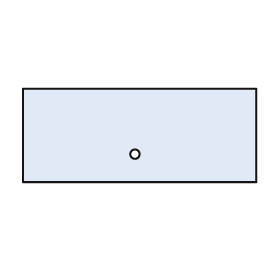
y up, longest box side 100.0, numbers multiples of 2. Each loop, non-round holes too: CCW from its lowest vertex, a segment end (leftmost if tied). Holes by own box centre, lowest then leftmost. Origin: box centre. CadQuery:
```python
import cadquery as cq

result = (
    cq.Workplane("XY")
    .moveTo(-50.0, -20.0)
    .lineTo(50.0, -20.0)
    .lineTo(50.0, 20.0)
    .lineTo(-50.0, 20.0)
    .close()
    .moveTo(-2.0, -8.0)
    .circle(2.0)
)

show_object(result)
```